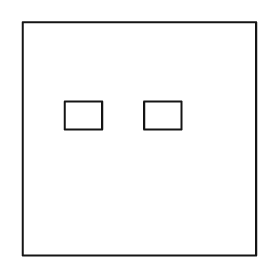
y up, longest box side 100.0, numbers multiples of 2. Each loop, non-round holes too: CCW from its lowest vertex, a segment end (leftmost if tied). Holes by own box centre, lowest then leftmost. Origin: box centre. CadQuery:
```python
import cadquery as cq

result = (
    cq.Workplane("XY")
    .moveTo(-50.0, -50.0)
    .lineTo(50.0, -50.0)
    .lineTo(50.0, 50.0)
    .lineTo(-50.0, 50.0)
    .close()
    .moveTo(-32.0, 4.0)
    .lineTo(-16.0, 4.0)
    .lineTo(-16.0, 16.0)
    .lineTo(-32.0, 16.0)
    .close()
    .moveTo(2.0, 4.0)
    .lineTo(18.0, 4.0)
    .lineTo(18.0, 16.0)
    .lineTo(2.0, 16.0)
    .close()
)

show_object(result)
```